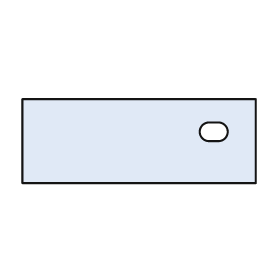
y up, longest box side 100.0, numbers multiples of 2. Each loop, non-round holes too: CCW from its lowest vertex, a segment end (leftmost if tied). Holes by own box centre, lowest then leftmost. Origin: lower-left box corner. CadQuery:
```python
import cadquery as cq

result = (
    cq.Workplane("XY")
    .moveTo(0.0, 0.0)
    .lineTo(100.0, 0.0)
    .lineTo(100.0, 36.0)
    .lineTo(0.0, 36.0)
    .close()
    .moveTo(80.0, 18.0)
    .lineTo(84.0, 18.0)
    .threePointArc((88.0, 22.0), (84.0, 26.0))
    .lineTo(80.0, 26.0)
    .threePointArc((76.0, 22.0), (80.0, 18.0))
    .close()
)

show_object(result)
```